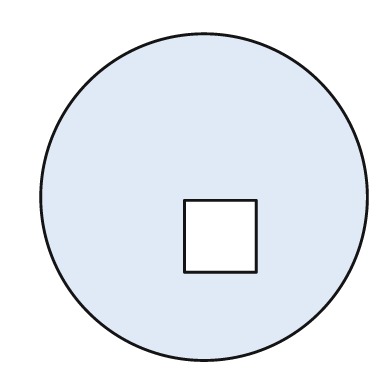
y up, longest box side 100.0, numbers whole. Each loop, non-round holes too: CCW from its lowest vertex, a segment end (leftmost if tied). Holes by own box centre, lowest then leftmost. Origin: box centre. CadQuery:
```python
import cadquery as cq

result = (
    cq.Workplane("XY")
    .moveTo(0.0, 0.0)
    .circle(50.0)
    .moveTo(-6.0, -23.0)
    .lineTo(16.0, -23.0)
    .lineTo(16.0, -1.0)
    .lineTo(-6.0, -1.0)
    .close()
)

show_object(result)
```